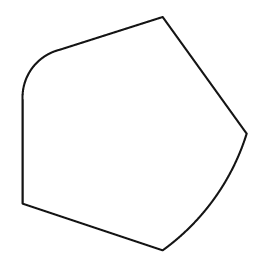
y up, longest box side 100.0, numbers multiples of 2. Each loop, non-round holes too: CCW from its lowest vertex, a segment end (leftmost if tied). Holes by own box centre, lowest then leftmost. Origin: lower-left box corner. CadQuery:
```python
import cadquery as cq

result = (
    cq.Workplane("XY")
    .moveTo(60.0, 0.0)
    .threePointArc((82.0, 22.0), (96.0, 50.0))
    .lineTo(60.0, 100.0)
    .lineTo(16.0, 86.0)
    .threePointArc((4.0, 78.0), (0.0, 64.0))
    .lineTo(0.0, 20.0)
    .close()
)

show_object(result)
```